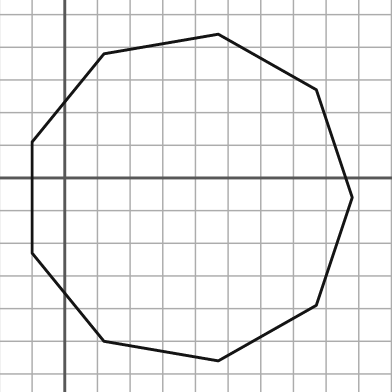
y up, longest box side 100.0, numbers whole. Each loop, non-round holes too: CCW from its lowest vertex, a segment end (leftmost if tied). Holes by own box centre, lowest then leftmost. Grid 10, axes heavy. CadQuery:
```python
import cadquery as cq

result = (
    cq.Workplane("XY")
    .moveTo(47.0, -56.0)
    .lineTo(77.0, -39.0)
    .lineTo(88.0, -6.0)
    .lineTo(77.0, 27.0)
    .lineTo(47.0, 44.0)
    .lineTo(12.0, 38.0)
    .lineTo(-10.0, 11.0)
    .lineTo(-10.0, -23.0)
    .lineTo(12.0, -50.0)
    .close()
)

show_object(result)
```